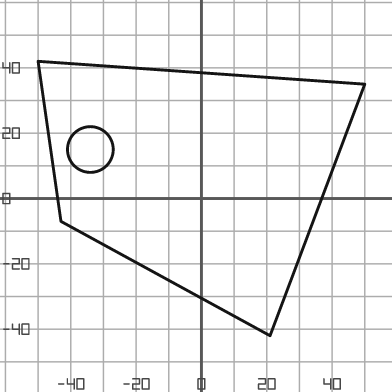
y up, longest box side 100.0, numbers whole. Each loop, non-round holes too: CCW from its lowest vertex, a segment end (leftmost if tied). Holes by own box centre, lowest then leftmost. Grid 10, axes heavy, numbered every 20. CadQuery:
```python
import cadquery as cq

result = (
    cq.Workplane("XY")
    .moveTo(21.0, -42.0)
    .lineTo(50.0, 35.0)
    .lineTo(-50.0, 42.0)
    .lineTo(-43.0, -7.0)
    .close()
    .moveTo(-34.0, 15.0)
    .circle(7.0)
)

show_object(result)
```